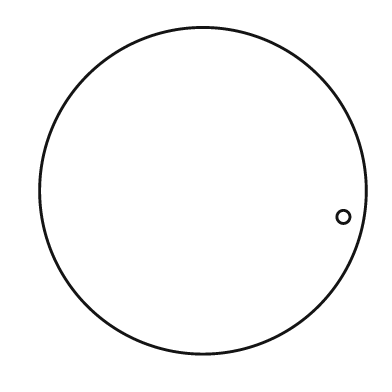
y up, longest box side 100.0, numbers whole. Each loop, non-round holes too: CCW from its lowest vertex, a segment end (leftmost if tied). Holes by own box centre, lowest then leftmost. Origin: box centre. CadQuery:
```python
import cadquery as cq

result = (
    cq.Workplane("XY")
    .moveTo(0.0, 0.0)
    .circle(50.0)
    .moveTo(43.0, -8.0)
    .circle(2.0)
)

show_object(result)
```